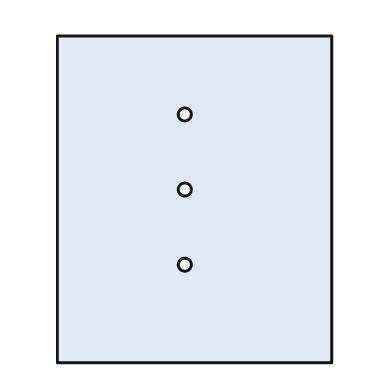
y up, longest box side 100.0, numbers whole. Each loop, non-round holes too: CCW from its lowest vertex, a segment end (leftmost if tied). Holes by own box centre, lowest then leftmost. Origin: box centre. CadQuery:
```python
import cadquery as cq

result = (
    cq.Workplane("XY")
    .moveTo(-42.0, -50.0)
    .lineTo(42.0, -50.0)
    .lineTo(42.0, 50.0)
    .lineTo(-42.0, 50.0)
    .close()
    .moveTo(-3.0, -20.0)
    .circle(2.0)
    .moveTo(-3.0, 3.0)
    .circle(2.0)
    .moveTo(-3.0, 26.0)
    .circle(2.0)
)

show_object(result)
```